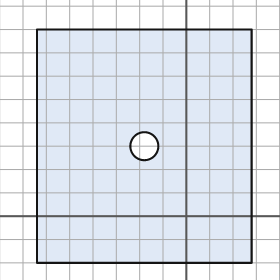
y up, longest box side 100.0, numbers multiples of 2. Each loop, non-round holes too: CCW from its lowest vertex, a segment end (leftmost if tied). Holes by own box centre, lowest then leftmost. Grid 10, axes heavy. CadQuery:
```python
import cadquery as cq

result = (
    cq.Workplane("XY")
    .moveTo(-64.0, -20.0)
    .lineTo(28.0, -20.0)
    .lineTo(28.0, 80.0)
    .lineTo(-64.0, 80.0)
    .close()
    .moveTo(-18.0, 30.0)
    .circle(6.0)
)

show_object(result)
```